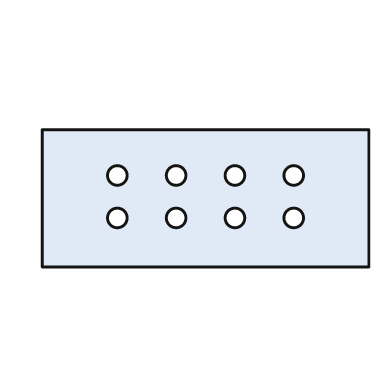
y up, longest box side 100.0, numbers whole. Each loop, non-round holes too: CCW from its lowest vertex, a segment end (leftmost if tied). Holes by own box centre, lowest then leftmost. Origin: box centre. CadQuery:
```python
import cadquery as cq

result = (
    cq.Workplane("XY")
    .moveTo(-50.0, -21.0)
    .lineTo(50.0, -21.0)
    .lineTo(50.0, 21.0)
    .lineTo(-50.0, 21.0)
    .close()
    .moveTo(-27.0, -6.0)
    .circle(3.0)
    .moveTo(-9.0, -6.0)
    .circle(3.0)
    .moveTo(9.0, -6.0)
    .circle(3.0)
    .moveTo(27.0, -6.0)
    .circle(3.0)
    .moveTo(-27.0, 7.0)
    .circle(3.0)
    .moveTo(-9.0, 7.0)
    .circle(3.0)
    .moveTo(9.0, 7.0)
    .circle(3.0)
    .moveTo(27.0, 7.0)
    .circle(3.0)
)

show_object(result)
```